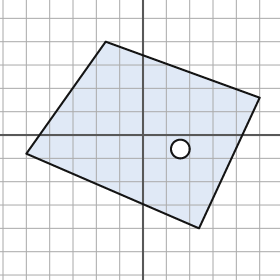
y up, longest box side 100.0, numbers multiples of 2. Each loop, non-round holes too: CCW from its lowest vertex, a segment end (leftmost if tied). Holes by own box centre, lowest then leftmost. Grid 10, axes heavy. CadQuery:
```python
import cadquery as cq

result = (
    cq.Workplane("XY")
    .moveTo(24.0, -40.0)
    .lineTo(50.0, 16.0)
    .lineTo(-16.0, 40.0)
    .lineTo(-50.0, -8.0)
    .close()
    .moveTo(16.0, -6.0)
    .circle(4.0)
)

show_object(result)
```